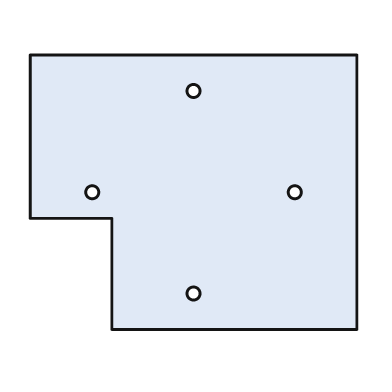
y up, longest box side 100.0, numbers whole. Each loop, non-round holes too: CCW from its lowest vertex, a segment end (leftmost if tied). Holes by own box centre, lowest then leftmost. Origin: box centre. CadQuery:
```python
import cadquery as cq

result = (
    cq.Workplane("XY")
    .moveTo(-25.0, -42.0)
    .lineTo(50.0, -42.0)
    .lineTo(50.0, 42.0)
    .lineTo(-50.0, 42.0)
    .lineTo(-50.0, -8.0)
    .lineTo(-25.0, -8.0)
    .close()
    .moveTo(0.0, -31.0)
    .circle(2.0)
    .moveTo(-31.0, 0.0)
    .circle(2.0)
    .moveTo(31.0, 0.0)
    .circle(2.0)
    .moveTo(0.0, 31.0)
    .circle(2.0)
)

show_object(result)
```